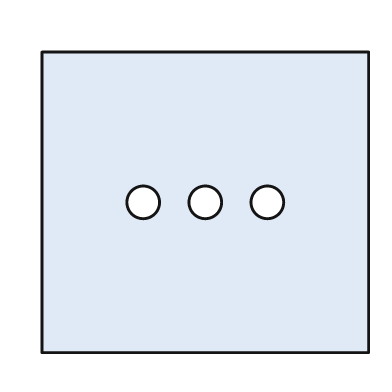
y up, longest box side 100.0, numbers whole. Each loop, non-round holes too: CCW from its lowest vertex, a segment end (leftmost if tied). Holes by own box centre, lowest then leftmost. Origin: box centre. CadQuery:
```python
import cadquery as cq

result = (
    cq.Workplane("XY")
    .moveTo(-50.0, -46.0)
    .lineTo(50.0, -46.0)
    .lineTo(50.0, 46.0)
    .lineTo(-50.0, 46.0)
    .close()
    .moveTo(-19.0, 0.0)
    .circle(5.0)
    .moveTo(0.0, 0.0)
    .circle(5.0)
    .moveTo(19.0, 0.0)
    .circle(5.0)
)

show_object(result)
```